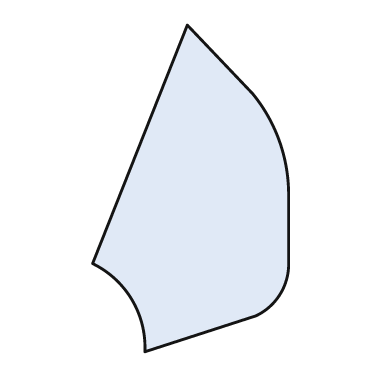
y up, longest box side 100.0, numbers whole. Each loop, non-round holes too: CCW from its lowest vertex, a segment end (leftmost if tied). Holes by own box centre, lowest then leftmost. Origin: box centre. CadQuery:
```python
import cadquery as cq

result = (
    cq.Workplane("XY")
    .moveTo(-14.0, -50.0)
    .lineTo(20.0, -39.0)
    .threePointArc((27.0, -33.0), (30.0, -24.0))
    .lineTo(30.0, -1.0)
    .threePointArc((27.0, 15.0), (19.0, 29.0))
    .lineTo(-1.0, 50.0)
    .lineTo(-30.0, -23.0)
    .threePointArc((-18.0, -34.0), (-14.0, -50.0))
    .close()
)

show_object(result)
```